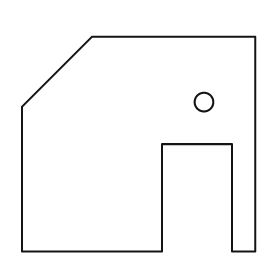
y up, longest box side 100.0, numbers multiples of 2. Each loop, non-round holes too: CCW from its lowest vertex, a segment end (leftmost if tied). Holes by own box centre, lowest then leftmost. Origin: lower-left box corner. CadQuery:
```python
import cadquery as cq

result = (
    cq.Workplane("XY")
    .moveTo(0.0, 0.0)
    .lineTo(60.0, 0.0)
    .lineTo(60.0, 46.0)
    .lineTo(90.0, 46.0)
    .lineTo(90.0, 0.0)
    .lineTo(100.0, 0.0)
    .lineTo(100.0, 92.0)
    .lineTo(30.0, 92.0)
    .lineTo(0.0, 62.0)
    .close()
    .moveTo(78.0, 64.0)
    .circle(4.0)
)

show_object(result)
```